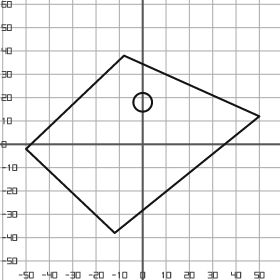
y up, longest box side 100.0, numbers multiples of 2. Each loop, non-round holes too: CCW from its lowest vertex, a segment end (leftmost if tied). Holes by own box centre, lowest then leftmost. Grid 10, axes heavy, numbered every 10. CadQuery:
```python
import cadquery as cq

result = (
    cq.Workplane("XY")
    .moveTo(-12.0, -38.0)
    .lineTo(50.0, 12.0)
    .lineTo(-8.0, 38.0)
    .lineTo(-50.0, -2.0)
    .close()
    .moveTo(0.0, 18.0)
    .circle(4.0)
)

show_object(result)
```